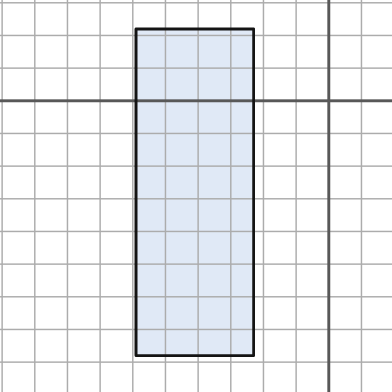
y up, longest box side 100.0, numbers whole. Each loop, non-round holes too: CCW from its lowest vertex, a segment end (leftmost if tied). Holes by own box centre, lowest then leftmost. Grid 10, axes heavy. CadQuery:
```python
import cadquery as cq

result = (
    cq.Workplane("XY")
    .moveTo(-59.0, -78.0)
    .lineTo(-23.0, -78.0)
    .lineTo(-23.0, 22.0)
    .lineTo(-59.0, 22.0)
    .close()
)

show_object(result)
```